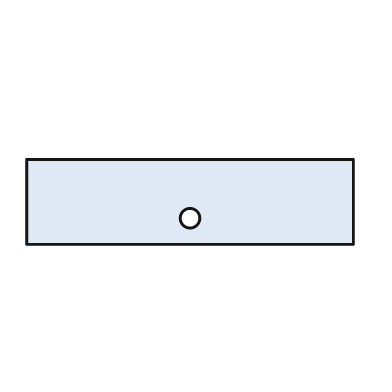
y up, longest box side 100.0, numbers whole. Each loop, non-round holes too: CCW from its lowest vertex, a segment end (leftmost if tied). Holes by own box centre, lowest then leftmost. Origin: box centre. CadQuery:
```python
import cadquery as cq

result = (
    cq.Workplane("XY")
    .moveTo(-50.0, -13.0)
    .lineTo(50.0, -13.0)
    .lineTo(50.0, 13.0)
    .lineTo(-50.0, 13.0)
    .close()
    .moveTo(0.0, -5.0)
    .circle(3.0)
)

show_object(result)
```